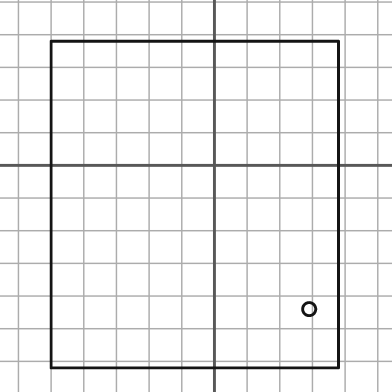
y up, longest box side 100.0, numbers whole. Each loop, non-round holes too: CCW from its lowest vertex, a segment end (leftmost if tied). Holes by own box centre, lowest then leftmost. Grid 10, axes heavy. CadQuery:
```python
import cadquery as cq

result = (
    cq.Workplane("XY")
    .moveTo(-50.0, -62.0)
    .lineTo(38.0, -62.0)
    .lineTo(38.0, 38.0)
    .lineTo(-50.0, 38.0)
    .close()
    .moveTo(29.0, -44.0)
    .circle(2.0)
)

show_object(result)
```